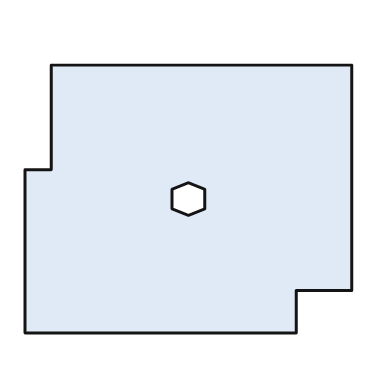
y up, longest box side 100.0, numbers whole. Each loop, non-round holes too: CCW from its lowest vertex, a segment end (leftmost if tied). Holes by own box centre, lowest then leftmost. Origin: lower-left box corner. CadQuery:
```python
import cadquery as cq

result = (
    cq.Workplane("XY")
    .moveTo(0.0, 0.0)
    .lineTo(83.0, 0.0)
    .lineTo(83.0, 13.0)
    .lineTo(100.0, 13.0)
    .lineTo(100.0, 82.0)
    .lineTo(8.0, 82.0)
    .lineTo(8.0, 50.0)
    .lineTo(0.0, 50.0)
    .close()
    .moveTo(50.0, 36.0)
    .lineTo(55.0, 38.0)
    .lineTo(55.0, 44.0)
    .lineTo(50.0, 46.0)
    .lineTo(45.0, 44.0)
    .lineTo(45.0, 38.0)
    .close()
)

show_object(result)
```